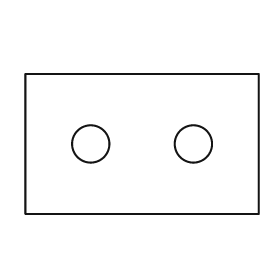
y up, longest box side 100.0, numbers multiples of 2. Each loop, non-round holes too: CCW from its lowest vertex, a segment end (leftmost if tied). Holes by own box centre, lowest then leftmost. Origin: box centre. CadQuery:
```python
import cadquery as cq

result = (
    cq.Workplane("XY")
    .moveTo(-50.0, -30.0)
    .lineTo(50.0, -30.0)
    .lineTo(50.0, 30.0)
    .lineTo(-50.0, 30.0)
    .close()
    .moveTo(-22.0, 0.0)
    .circle(8.0)
    .moveTo(22.0, 0.0)
    .circle(8.0)
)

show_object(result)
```